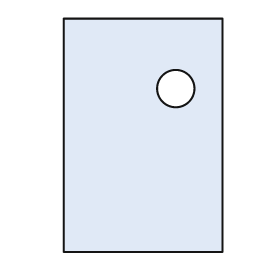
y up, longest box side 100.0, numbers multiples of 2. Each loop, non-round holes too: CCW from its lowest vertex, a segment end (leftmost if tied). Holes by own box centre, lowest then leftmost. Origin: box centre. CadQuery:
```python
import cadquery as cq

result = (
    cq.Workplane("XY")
    .moveTo(-34.0, -50.0)
    .lineTo(34.0, -50.0)
    .lineTo(34.0, 50.0)
    .lineTo(-34.0, 50.0)
    .close()
    .moveTo(14.0, 20.0)
    .circle(8.0)
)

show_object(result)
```